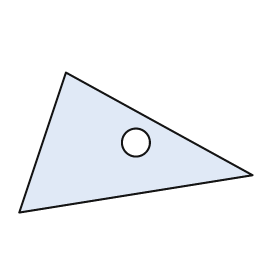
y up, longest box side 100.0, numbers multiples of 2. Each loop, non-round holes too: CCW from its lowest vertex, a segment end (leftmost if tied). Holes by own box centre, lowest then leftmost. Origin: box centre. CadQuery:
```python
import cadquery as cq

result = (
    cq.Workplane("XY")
    .moveTo(-50.0, -30.0)
    .lineTo(50.0, -14.0)
    .lineTo(-30.0, 30.0)
    .close()
    .moveTo(0.0, 0.0)
    .circle(6.0)
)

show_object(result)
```